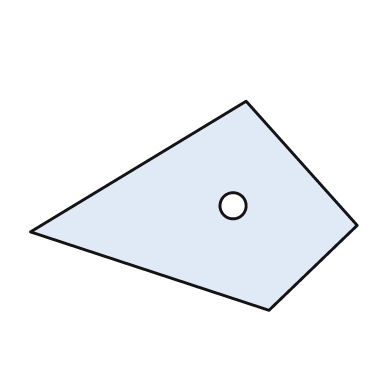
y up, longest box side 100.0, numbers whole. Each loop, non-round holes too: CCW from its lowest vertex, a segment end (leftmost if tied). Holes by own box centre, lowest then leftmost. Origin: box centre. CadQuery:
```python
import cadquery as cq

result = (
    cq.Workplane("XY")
    .moveTo(23.0, -32.0)
    .lineTo(50.0, -6.0)
    .lineTo(16.0, 32.0)
    .lineTo(-50.0, -8.0)
    .close()
    .moveTo(12.0, 0.0)
    .circle(4.0)
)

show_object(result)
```